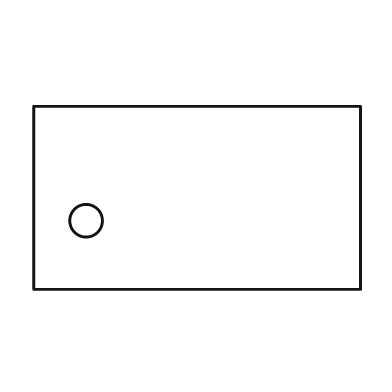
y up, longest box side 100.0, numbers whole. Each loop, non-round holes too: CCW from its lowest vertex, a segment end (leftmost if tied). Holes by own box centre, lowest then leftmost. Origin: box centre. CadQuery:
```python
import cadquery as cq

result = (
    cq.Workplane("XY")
    .moveTo(-50.0, -28.0)
    .lineTo(50.0, -28.0)
    .lineTo(50.0, 28.0)
    .lineTo(-50.0, 28.0)
    .close()
    .moveTo(-34.0, -7.0)
    .circle(5.0)
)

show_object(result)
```